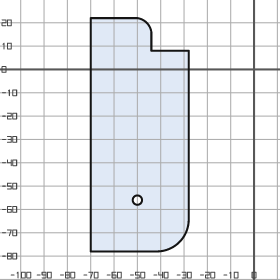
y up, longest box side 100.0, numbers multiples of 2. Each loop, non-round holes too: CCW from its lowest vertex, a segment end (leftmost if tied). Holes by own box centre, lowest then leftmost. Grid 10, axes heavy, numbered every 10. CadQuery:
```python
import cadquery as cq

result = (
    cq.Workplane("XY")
    .moveTo(-70.0, -78.0)
    .lineTo(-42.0, -78.0)
    .threePointArc((-32.0, -74.0), (-28.0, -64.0))
    .lineTo(-28.0, 8.0)
    .lineTo(-44.0, 8.0)
    .lineTo(-44.0, 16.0)
    .threePointArc((-46.0, 20.0), (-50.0, 22.0))
    .lineTo(-70.0, 22.0)
    .close()
    .moveTo(-50.0, -56.0)
    .circle(2.0)
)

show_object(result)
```